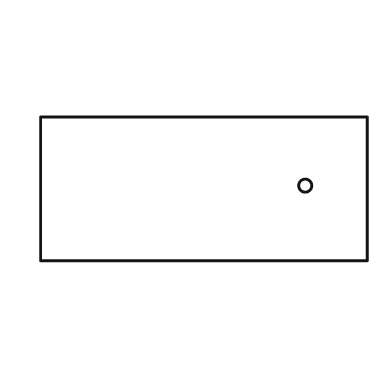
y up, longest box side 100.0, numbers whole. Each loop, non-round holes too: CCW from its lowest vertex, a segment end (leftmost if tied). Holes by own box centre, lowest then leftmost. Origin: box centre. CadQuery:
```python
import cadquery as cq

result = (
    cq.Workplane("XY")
    .moveTo(-50.0, -22.0)
    .lineTo(50.0, -22.0)
    .lineTo(50.0, 22.0)
    .lineTo(-50.0, 22.0)
    .close()
    .moveTo(31.0, 1.0)
    .circle(2.0)
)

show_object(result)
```